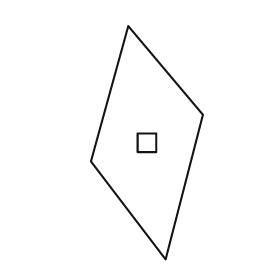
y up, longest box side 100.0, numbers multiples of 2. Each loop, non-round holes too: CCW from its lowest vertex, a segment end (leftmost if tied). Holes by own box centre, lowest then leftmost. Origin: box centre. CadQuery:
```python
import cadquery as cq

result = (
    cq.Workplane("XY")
    .moveTo(8.0, -50.0)
    .lineTo(24.0, 12.0)
    .lineTo(-8.0, 50.0)
    .lineTo(-24.0, -8.0)
    .close()
    .moveTo(-4.0, -4.0)
    .lineTo(4.0, -4.0)
    .lineTo(4.0, 4.0)
    .lineTo(-4.0, 4.0)
    .close()
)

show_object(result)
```